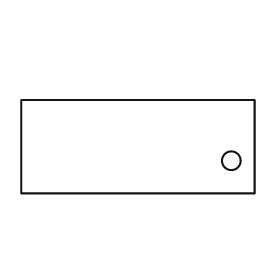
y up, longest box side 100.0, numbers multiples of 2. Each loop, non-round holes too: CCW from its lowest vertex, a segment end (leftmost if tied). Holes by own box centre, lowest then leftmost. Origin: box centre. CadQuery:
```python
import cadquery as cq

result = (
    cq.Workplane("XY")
    .moveTo(-50.0, -20.0)
    .lineTo(50.0, -20.0)
    .lineTo(50.0, 20.0)
    .lineTo(-50.0, 20.0)
    .close()
    .moveTo(40.0, -6.0)
    .circle(4.0)
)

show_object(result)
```